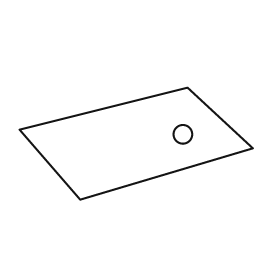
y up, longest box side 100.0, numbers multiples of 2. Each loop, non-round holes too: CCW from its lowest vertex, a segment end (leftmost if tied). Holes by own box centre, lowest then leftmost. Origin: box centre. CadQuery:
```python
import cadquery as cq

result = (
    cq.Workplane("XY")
    .moveTo(-24.0, -24.0)
    .lineTo(50.0, -2.0)
    .lineTo(22.0, 24.0)
    .lineTo(-50.0, 6.0)
    .close()
    .moveTo(20.0, 4.0)
    .circle(4.0)
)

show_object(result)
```